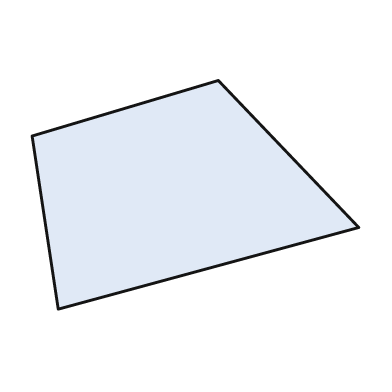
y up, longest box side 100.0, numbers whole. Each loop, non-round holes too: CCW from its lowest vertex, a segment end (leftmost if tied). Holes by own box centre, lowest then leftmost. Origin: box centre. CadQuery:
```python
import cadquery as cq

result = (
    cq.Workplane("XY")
    .moveTo(-42.0, -35.0)
    .lineTo(50.0, -10.0)
    .lineTo(7.0, 35.0)
    .lineTo(-50.0, 18.0)
    .close()
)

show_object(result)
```